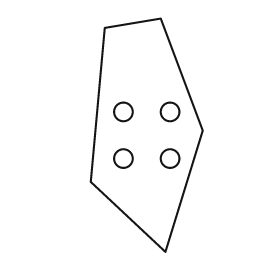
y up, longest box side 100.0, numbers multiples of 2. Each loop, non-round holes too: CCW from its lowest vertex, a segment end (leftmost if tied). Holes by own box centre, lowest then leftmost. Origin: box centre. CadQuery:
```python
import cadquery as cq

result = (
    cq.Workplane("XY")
    .moveTo(8.0, -50.0)
    .lineTo(24.0, 2.0)
    .lineTo(6.0, 50.0)
    .lineTo(-18.0, 46.0)
    .lineTo(-24.0, -20.0)
    .close()
    .moveTo(-10.0, -10.0)
    .circle(4.0)
    .moveTo(10.0, -10.0)
    .circle(4.0)
    .moveTo(-10.0, 10.0)
    .circle(4.0)
    .moveTo(10.0, 10.0)
    .circle(4.0)
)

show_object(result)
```